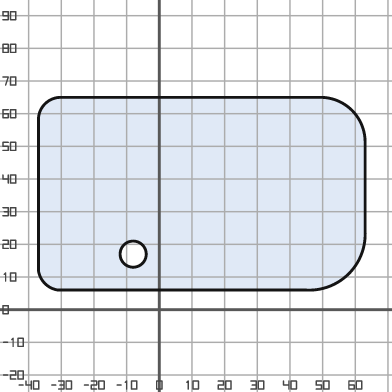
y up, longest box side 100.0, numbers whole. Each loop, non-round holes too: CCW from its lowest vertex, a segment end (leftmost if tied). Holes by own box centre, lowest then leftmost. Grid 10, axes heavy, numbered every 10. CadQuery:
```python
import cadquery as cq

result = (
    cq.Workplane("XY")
    .moveTo(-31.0, 6.0)
    .lineTo(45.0, 6.0)
    .threePointArc((58.0, 11.0), (63.0, 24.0))
    .lineTo(63.0, 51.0)
    .threePointArc((59.0, 61.0), (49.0, 65.0))
    .lineTo(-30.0, 65.0)
    .threePointArc((-35.0, 63.0), (-37.0, 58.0))
    .lineTo(-37.0, 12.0)
    .threePointArc((-35.0, 8.0), (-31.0, 6.0))
    .close()
    .moveTo(-8.0, 17.0)
    .circle(4.0)
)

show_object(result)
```